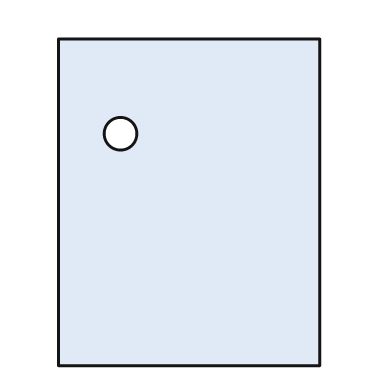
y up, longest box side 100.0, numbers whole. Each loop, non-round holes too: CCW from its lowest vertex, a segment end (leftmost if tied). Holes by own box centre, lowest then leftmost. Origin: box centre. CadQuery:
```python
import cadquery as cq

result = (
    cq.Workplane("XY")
    .moveTo(-40.0, -50.0)
    .lineTo(40.0, -50.0)
    .lineTo(40.0, 50.0)
    .lineTo(-40.0, 50.0)
    .close()
    .moveTo(-21.0, 21.0)
    .circle(5.0)
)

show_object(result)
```